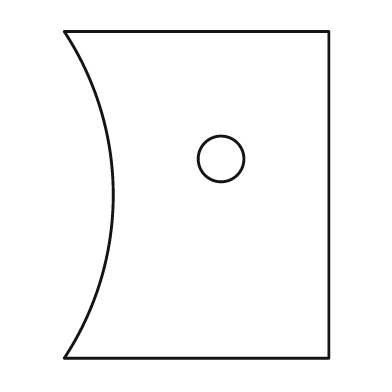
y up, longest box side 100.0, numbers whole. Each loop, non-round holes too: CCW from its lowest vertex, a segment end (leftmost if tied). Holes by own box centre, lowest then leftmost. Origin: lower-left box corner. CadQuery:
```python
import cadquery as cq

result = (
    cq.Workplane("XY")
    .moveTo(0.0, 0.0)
    .lineTo(81.0, 0.0)
    .lineTo(81.0, 100.0)
    .lineTo(0.0, 100.0)
    .threePointArc((15.0, 50.0), (0.0, 0.0))
    .close()
    .moveTo(48.0, 61.0)
    .circle(7.0)
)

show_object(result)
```